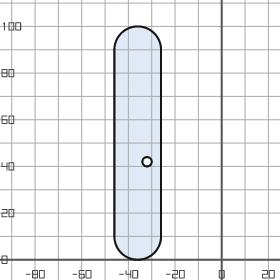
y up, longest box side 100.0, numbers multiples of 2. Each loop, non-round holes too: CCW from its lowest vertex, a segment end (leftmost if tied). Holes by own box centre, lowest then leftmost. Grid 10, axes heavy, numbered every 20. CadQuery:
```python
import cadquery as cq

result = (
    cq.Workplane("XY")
    .moveTo(-46.0, 10.0)
    .threePointArc((-36.0, 0.0), (-26.0, 10.0))
    .lineTo(-26.0, 90.0)
    .threePointArc((-36.0, 100.0), (-46.0, 90.0))
    .close()
    .moveTo(-32.0, 42.0)
    .circle(2.0)
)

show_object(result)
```